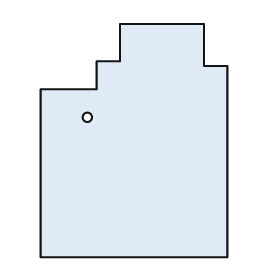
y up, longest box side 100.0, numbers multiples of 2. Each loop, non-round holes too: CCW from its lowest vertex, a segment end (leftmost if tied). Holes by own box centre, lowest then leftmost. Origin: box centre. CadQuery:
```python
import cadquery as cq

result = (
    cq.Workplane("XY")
    .moveTo(-40.0, -50.0)
    .lineTo(40.0, -50.0)
    .lineTo(40.0, 32.0)
    .lineTo(30.0, 32.0)
    .lineTo(30.0, 50.0)
    .lineTo(-6.0, 50.0)
    .lineTo(-6.0, 34.0)
    .lineTo(-16.0, 34.0)
    .lineTo(-16.0, 22.0)
    .lineTo(-40.0, 22.0)
    .close()
    .moveTo(-20.0, 10.0)
    .circle(2.0)
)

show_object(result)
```